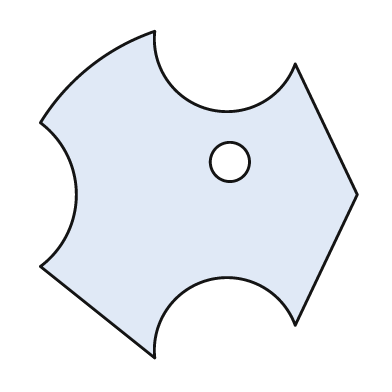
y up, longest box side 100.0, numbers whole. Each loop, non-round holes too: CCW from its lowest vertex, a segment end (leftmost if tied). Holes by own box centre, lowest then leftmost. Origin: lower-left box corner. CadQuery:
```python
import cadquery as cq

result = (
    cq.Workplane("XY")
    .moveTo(35.0, 0.0)
    .threePointArc((52.0, 24.0), (78.0, 10.0))
    .lineTo(97.0, 50.0)
    .lineTo(78.0, 90.0)
    .threePointArc((52.0, 76.0), (35.0, 100.0))
    .threePointArc((15.0, 89.0), (0.0, 72.0))
    .threePointArc((11.0, 50.0), (0.0, 28.0))
    .close()
    .moveTo(58.0, 60.0)
    .circle(6.0)
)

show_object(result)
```